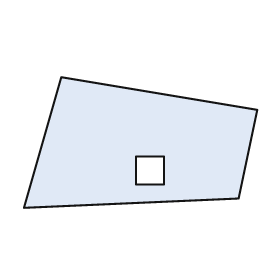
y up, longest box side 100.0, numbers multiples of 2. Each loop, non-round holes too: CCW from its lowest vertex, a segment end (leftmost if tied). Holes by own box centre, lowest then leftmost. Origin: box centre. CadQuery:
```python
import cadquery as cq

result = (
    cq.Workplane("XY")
    .moveTo(-50.0, -28.0)
    .lineTo(42.0, -24.0)
    .lineTo(50.0, 14.0)
    .lineTo(-34.0, 28.0)
    .close()
    .moveTo(-2.0, -18.0)
    .lineTo(10.0, -18.0)
    .lineTo(10.0, -6.0)
    .lineTo(-2.0, -6.0)
    .close()
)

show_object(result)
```